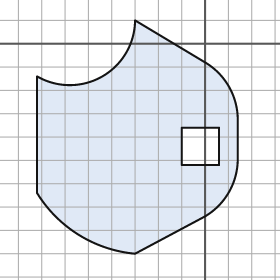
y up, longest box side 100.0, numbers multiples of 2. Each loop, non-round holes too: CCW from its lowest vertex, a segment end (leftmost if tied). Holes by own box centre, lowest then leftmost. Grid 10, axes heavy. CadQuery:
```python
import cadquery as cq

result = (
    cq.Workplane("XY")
    .moveTo(-30.0, -90.0)
    .lineTo(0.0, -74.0)
    .threePointArc((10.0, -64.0), (14.0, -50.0))
    .lineTo(14.0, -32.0)
    .threePointArc((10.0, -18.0), (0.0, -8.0))
    .lineTo(-30.0, 10.0)
    .threePointArc((-44.0, -14.0), (-72.0, -14.0))
    .lineTo(-72.0, -64.0)
    .threePointArc((-54.0, -82.0), (-30.0, -90.0))
    .close()
    .moveTo(-10.0, -52.0)
    .lineTo(6.0, -52.0)
    .lineTo(6.0, -36.0)
    .lineTo(-10.0, -36.0)
    .close()
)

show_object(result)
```